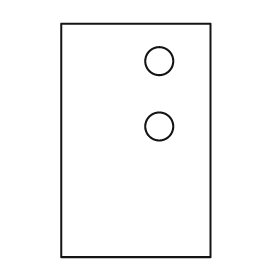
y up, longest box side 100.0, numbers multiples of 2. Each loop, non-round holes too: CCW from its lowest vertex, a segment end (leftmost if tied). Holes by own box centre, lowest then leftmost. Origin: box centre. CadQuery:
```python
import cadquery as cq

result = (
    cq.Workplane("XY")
    .moveTo(-32.0, -50.0)
    .lineTo(32.0, -50.0)
    .lineTo(32.0, 50.0)
    .lineTo(-32.0, 50.0)
    .close()
    .moveTo(10.0, 6.0)
    .circle(6.0)
    .moveTo(10.0, 34.0)
    .circle(6.0)
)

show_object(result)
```